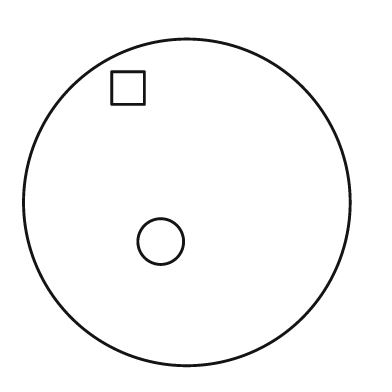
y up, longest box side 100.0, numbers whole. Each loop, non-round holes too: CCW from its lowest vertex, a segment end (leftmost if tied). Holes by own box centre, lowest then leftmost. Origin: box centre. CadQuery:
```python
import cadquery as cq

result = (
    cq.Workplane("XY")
    .moveTo(0.0, 0.0)
    .circle(50.0)
    .moveTo(-8.0, -12.0)
    .circle(7.0)
    .moveTo(-23.0, 30.0)
    .lineTo(-13.0, 30.0)
    .lineTo(-13.0, 40.0)
    .lineTo(-23.0, 40.0)
    .close()
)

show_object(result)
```